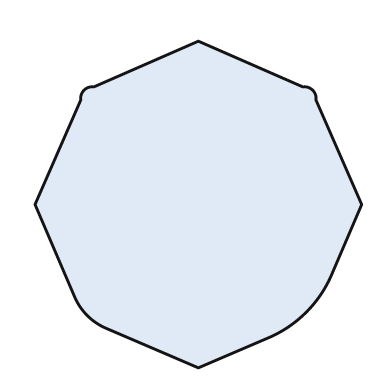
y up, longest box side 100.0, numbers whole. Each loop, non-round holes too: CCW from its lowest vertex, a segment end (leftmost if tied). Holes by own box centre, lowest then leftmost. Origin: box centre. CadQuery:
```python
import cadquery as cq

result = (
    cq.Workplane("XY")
    .moveTo(0.0, -50.0)
    .lineTo(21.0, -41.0)
    .threePointArc((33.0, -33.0), (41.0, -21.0))
    .lineTo(50.0, 0.0)
    .lineTo(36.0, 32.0)
    .threePointArc((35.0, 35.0), (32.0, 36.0))
    .lineTo(0.0, 50.0)
    .lineTo(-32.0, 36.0)
    .threePointArc((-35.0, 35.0), (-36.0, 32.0))
    .lineTo(-50.0, 0.0)
    .lineTo(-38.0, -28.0)
    .threePointArc((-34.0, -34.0), (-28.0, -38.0))
    .close()
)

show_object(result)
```